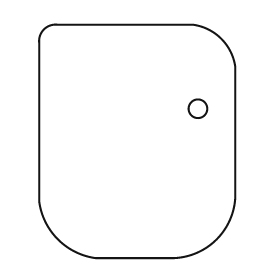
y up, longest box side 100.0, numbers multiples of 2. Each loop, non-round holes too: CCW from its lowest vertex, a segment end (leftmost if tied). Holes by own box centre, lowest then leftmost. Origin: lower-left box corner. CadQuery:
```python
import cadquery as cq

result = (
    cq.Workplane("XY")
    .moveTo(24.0, 0.0)
    .lineTo(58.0, 0.0)
    .threePointArc((76.0, 8.0), (84.0, 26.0))
    .lineTo(84.0, 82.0)
    .threePointArc((78.0, 94.0), (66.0, 100.0))
    .lineTo(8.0, 100.0)
    .threePointArc((2.0, 98.0), (0.0, 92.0))
    .lineTo(0.0, 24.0)
    .threePointArc((8.0, 8.0), (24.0, 0.0))
    .close()
    .moveTo(68.0, 64.0)
    .circle(4.0)
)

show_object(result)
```